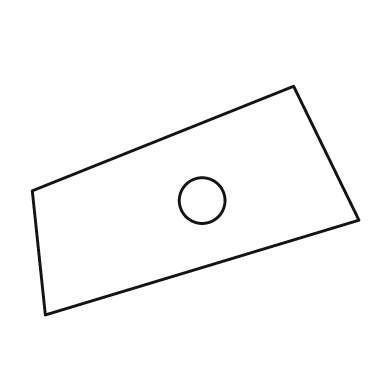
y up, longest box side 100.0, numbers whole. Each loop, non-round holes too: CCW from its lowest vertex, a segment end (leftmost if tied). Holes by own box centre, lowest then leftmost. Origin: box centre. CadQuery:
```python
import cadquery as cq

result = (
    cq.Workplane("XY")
    .moveTo(-46.0, -35.0)
    .lineTo(50.0, -6.0)
    .lineTo(30.0, 35.0)
    .lineTo(-50.0, 3.0)
    .close()
    .moveTo(2.0, 0.0)
    .circle(7.0)
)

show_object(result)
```